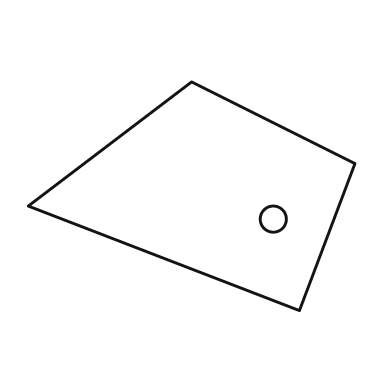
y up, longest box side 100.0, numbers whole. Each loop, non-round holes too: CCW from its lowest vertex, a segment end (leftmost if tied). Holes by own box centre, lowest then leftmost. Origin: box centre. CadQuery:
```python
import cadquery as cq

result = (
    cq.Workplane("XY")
    .moveTo(33.0, -35.0)
    .lineTo(50.0, 10.0)
    .lineTo(0.0, 35.0)
    .lineTo(-50.0, -3.0)
    .close()
    .moveTo(25.0, -7.0)
    .circle(4.0)
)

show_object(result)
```